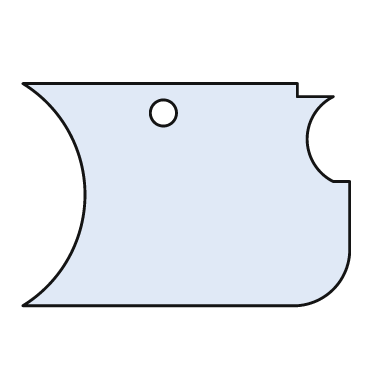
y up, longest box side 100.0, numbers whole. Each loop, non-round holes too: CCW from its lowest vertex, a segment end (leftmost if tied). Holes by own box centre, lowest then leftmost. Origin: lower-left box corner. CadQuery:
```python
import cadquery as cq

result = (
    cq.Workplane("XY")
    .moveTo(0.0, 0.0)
    .lineTo(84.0, 0.0)
    .threePointArc((95.0, 5.0), (100.0, 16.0))
    .lineTo(100.0, 38.0)
    .lineTo(95.0, 38.0)
    .threePointArc((87.0, 51.0), (95.0, 64.0))
    .lineTo(84.0, 64.0)
    .lineTo(84.0, 68.0)
    .lineTo(0.0, 68.0)
    .threePointArc((19.0, 34.0), (0.0, 0.0))
    .close()
    .moveTo(43.0, 59.0)
    .circle(4.0)
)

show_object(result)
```